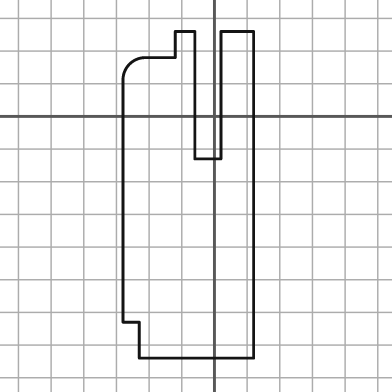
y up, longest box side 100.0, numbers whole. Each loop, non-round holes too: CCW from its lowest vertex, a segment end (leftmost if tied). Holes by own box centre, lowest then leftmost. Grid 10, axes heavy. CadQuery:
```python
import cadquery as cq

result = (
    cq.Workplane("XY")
    .moveTo(-23.0, -74.0)
    .lineTo(12.0, -74.0)
    .lineTo(12.0, 26.0)
    .lineTo(2.0, 26.0)
    .lineTo(2.0, -13.0)
    .lineTo(-6.0, -13.0)
    .lineTo(-6.0, 26.0)
    .lineTo(-12.0, 26.0)
    .lineTo(-12.0, 18.0)
    .lineTo(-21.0, 18.0)
    .threePointArc((-26.0, 16.0), (-28.0, 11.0))
    .lineTo(-28.0, -63.0)
    .lineTo(-23.0, -63.0)
    .close()
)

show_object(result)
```